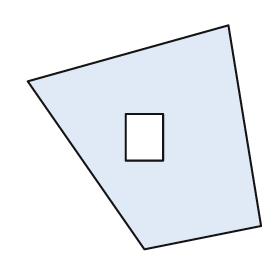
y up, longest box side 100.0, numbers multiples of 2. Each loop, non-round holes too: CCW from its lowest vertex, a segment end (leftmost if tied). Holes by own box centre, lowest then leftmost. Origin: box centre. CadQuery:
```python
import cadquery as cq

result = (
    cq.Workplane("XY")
    .moveTo(0.0, -48.0)
    .lineTo(50.0, -38.0)
    .lineTo(36.0, 48.0)
    .lineTo(-50.0, 24.0)
    .close()
    .moveTo(-8.0, -10.0)
    .lineTo(8.0, -10.0)
    .lineTo(8.0, 10.0)
    .lineTo(-8.0, 10.0)
    .close()
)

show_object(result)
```